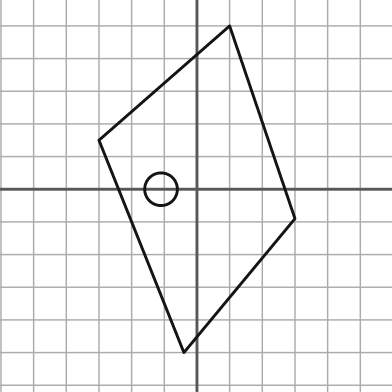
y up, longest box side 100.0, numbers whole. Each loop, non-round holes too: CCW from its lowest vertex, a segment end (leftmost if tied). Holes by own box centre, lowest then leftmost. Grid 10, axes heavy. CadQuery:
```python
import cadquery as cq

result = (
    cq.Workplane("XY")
    .moveTo(-4.0, -50.0)
    .lineTo(30.0, -9.0)
    .lineTo(10.0, 50.0)
    .lineTo(-30.0, 15.0)
    .close()
    .moveTo(-11.0, 0.0)
    .circle(5.0)
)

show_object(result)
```